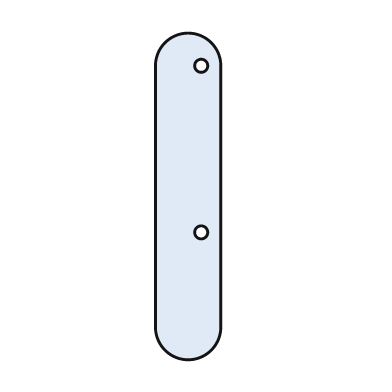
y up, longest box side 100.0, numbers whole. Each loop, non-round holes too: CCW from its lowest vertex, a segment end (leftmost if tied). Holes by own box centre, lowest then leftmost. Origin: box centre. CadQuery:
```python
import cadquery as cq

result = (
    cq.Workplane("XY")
    .moveTo(-10.0, -40.0)
    .threePointArc((0.0, -50.0), (10.0, -40.0))
    .lineTo(10.0, 40.0)
    .threePointArc((0.0, 50.0), (-10.0, 40.0))
    .close()
    .moveTo(4.0, -11.0)
    .circle(2.0)
    .moveTo(4.0, 40.0)
    .circle(2.0)
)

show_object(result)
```